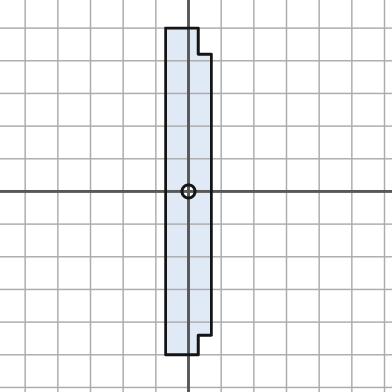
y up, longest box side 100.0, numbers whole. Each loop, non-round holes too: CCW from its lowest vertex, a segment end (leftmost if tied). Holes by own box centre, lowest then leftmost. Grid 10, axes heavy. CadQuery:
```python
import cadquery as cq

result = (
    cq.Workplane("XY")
    .moveTo(-7.0, -50.0)
    .lineTo(3.0, -50.0)
    .lineTo(3.0, -44.0)
    .lineTo(7.0, -44.0)
    .lineTo(7.0, 42.0)
    .lineTo(3.0, 42.0)
    .lineTo(3.0, 50.0)
    .lineTo(-7.0, 50.0)
    .close()
    .moveTo(0.0, 0.0)
    .circle(2.0)
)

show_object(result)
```